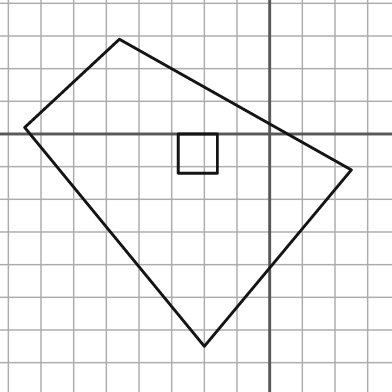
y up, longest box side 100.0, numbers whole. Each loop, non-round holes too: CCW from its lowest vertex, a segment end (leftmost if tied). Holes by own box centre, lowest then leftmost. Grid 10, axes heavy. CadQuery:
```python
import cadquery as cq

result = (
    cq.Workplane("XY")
    .moveTo(-20.0, -65.0)
    .lineTo(25.0, -11.0)
    .lineTo(-46.0, 29.0)
    .lineTo(-75.0, 2.0)
    .close()
    .moveTo(-28.0, -12.0)
    .lineTo(-16.0, -12.0)
    .lineTo(-16.0, 0.0)
    .lineTo(-28.0, 0.0)
    .close()
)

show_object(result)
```